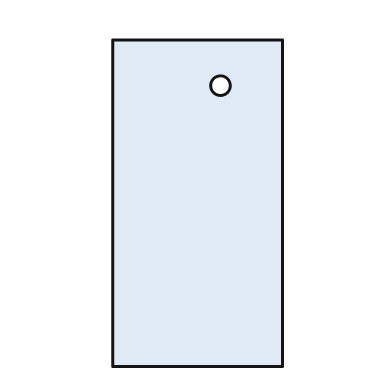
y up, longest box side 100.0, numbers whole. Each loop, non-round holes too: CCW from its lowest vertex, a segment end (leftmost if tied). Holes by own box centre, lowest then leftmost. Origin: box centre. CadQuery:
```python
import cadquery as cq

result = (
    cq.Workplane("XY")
    .moveTo(-26.0, -50.0)
    .lineTo(26.0, -50.0)
    .lineTo(26.0, 50.0)
    .lineTo(-26.0, 50.0)
    .close()
    .moveTo(7.0, 36.0)
    .circle(3.0)
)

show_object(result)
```